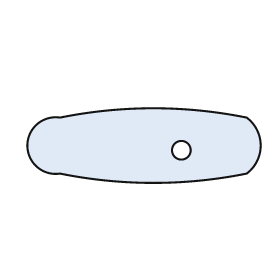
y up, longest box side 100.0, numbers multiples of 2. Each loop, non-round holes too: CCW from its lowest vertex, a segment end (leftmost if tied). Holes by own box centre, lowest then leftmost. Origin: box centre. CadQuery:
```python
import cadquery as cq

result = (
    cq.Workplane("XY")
    .moveTo(-36.0, -12.0)
    .threePointArc((4.0, -16.0), (44.0, -12.0))
    .threePointArc((50.0, 0.0), (44.0, 12.0))
    .threePointArc((4.0, 16.0), (-36.0, 12.0))
    .threePointArc((-50.0, 0.0), (-36.0, -12.0))
    .close()
    .moveTo(16.0, -2.0)
    .circle(4.0)
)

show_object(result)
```